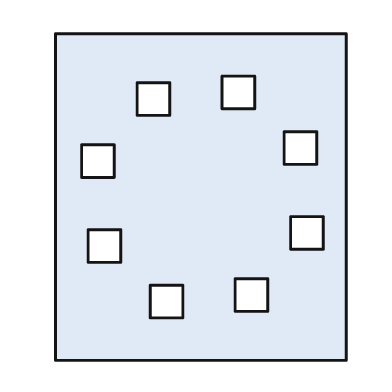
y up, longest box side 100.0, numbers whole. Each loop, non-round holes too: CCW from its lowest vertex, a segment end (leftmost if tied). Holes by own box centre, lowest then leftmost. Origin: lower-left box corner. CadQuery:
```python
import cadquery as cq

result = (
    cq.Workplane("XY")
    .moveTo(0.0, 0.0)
    .lineTo(89.0, 0.0)
    .lineTo(89.0, 100.0)
    .lineTo(0.0, 100.0)
    .close()
    .moveTo(29.0, 13.0)
    .lineTo(39.0, 13.0)
    .lineTo(39.0, 23.0)
    .lineTo(29.0, 23.0)
    .close()
    .moveTo(55.0, 15.0)
    .lineTo(65.0, 15.0)
    .lineTo(65.0, 25.0)
    .lineTo(55.0, 25.0)
    .close()
    .moveTo(10.0, 30.0)
    .lineTo(20.0, 30.0)
    .lineTo(20.0, 40.0)
    .lineTo(10.0, 40.0)
    .close()
    .moveTo(72.0, 34.0)
    .lineTo(82.0, 34.0)
    .lineTo(82.0, 44.0)
    .lineTo(72.0, 44.0)
    .close()
    .moveTo(8.0, 56.0)
    .lineTo(18.0, 56.0)
    .lineTo(18.0, 66.0)
    .lineTo(8.0, 66.0)
    .close()
    .moveTo(70.0, 60.0)
    .lineTo(80.0, 60.0)
    .lineTo(80.0, 70.0)
    .lineTo(70.0, 70.0)
    .close()
    .moveTo(25.0, 75.0)
    .lineTo(35.0, 75.0)
    .lineTo(35.0, 85.0)
    .lineTo(25.0, 85.0)
    .close()
    .moveTo(51.0, 77.0)
    .lineTo(61.0, 77.0)
    .lineTo(61.0, 87.0)
    .lineTo(51.0, 87.0)
    .close()
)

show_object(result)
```